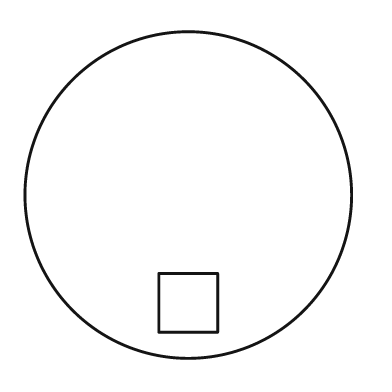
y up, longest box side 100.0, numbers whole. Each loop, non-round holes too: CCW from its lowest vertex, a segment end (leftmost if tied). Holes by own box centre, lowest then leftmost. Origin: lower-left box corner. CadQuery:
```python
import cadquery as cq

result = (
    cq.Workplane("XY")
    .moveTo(50.0, 50.0)
    .circle(50.0)
    .moveTo(41.0, 8.0)
    .lineTo(59.0, 8.0)
    .lineTo(59.0, 26.0)
    .lineTo(41.0, 26.0)
    .close()
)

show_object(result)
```